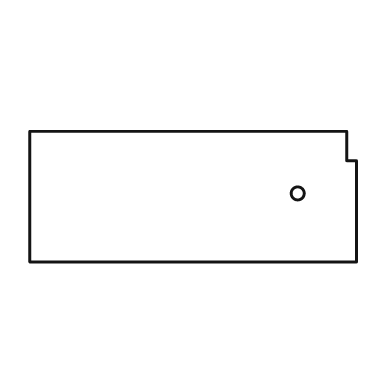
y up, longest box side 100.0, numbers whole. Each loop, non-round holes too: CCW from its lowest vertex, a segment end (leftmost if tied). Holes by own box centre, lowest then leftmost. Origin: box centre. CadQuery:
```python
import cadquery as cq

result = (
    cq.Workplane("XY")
    .moveTo(-50.0, -20.0)
    .lineTo(50.0, -20.0)
    .lineTo(50.0, 11.0)
    .lineTo(47.0, 11.0)
    .lineTo(47.0, 20.0)
    .lineTo(-50.0, 20.0)
    .close()
    .moveTo(32.0, 1.0)
    .circle(2.0)
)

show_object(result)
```